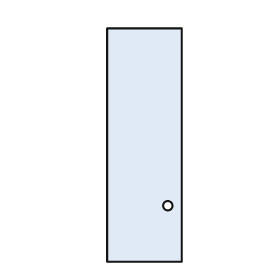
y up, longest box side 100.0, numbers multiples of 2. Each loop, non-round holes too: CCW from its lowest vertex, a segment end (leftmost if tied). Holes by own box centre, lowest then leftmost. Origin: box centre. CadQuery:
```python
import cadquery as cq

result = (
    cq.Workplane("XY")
    .moveTo(-16.0, -50.0)
    .lineTo(16.0, -50.0)
    .lineTo(16.0, 50.0)
    .lineTo(-16.0, 50.0)
    .close()
    .moveTo(10.0, -26.0)
    .circle(2.0)
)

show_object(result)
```